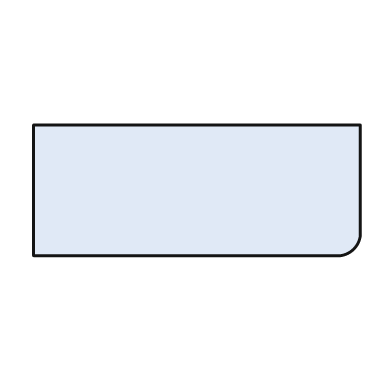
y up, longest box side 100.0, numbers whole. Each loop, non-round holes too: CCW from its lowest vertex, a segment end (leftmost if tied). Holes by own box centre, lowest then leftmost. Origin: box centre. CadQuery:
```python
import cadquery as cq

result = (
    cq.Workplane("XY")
    .moveTo(-50.0, -20.0)
    .lineTo(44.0, -20.0)
    .threePointArc((48.0, -18.0), (50.0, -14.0))
    .lineTo(50.0, 20.0)
    .lineTo(-50.0, 20.0)
    .close()
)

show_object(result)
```